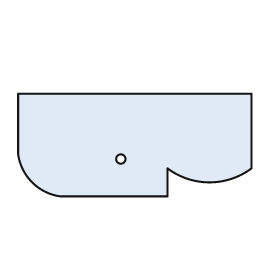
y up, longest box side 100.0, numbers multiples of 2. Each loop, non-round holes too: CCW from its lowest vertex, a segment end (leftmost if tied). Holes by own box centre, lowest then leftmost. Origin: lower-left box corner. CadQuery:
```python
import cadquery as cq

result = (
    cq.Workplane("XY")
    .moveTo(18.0, 0.0)
    .lineTo(64.0, 0.0)
    .lineTo(64.0, 12.0)
    .threePointArc((82.0, 6.0), (100.0, 12.0))
    .lineTo(100.0, 44.0)
    .lineTo(0.0, 44.0)
    .lineTo(0.0, 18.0)
    .threePointArc((6.0, 6.0), (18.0, 0.0))
    .close()
    .moveTo(44.0, 16.0)
    .circle(2.0)
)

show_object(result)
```